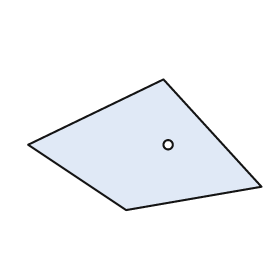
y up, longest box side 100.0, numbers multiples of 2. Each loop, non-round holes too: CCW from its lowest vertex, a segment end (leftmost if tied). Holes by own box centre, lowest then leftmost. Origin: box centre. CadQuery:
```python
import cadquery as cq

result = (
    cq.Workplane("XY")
    .moveTo(-8.0, -28.0)
    .lineTo(50.0, -18.0)
    .lineTo(8.0, 28.0)
    .lineTo(-50.0, 0.0)
    .close()
    .moveTo(10.0, 0.0)
    .circle(2.0)
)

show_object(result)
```